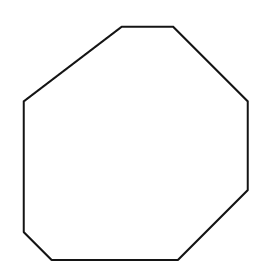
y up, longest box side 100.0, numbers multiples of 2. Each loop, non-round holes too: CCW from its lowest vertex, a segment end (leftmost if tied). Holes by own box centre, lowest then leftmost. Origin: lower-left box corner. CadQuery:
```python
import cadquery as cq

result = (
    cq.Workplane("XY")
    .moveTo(12.0, 0.0)
    .lineTo(66.0, 0.0)
    .lineTo(96.0, 30.0)
    .lineTo(96.0, 68.0)
    .lineTo(64.0, 100.0)
    .lineTo(42.0, 100.0)
    .lineTo(0.0, 68.0)
    .lineTo(0.0, 12.0)
    .close()
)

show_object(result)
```